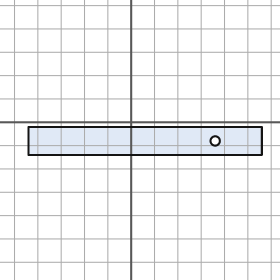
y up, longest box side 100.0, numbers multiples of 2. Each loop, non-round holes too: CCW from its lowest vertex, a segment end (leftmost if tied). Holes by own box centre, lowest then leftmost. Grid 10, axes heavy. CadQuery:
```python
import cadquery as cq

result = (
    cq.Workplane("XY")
    .moveTo(-44.0, -14.0)
    .lineTo(56.0, -14.0)
    .lineTo(56.0, -2.0)
    .lineTo(-44.0, -2.0)
    .close()
    .moveTo(36.0, -8.0)
    .circle(2.0)
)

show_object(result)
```